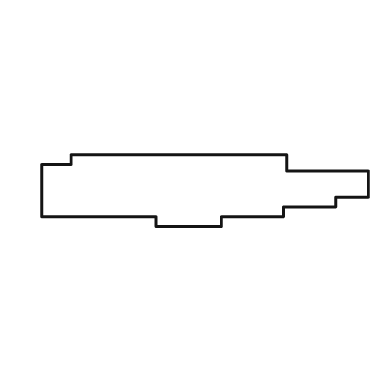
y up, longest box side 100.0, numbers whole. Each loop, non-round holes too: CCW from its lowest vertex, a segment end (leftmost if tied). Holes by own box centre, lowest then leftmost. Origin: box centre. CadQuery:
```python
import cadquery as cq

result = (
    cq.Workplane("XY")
    .moveTo(-15.0, -11.0)
    .lineTo(5.0, -11.0)
    .lineTo(5.0, -8.0)
    .lineTo(24.0, -8.0)
    .lineTo(24.0, -5.0)
    .lineTo(40.0, -5.0)
    .lineTo(40.0, -2.0)
    .lineTo(50.0, -2.0)
    .lineTo(50.0, 6.0)
    .lineTo(25.0, 6.0)
    .lineTo(25.0, 11.0)
    .lineTo(-41.0, 11.0)
    .lineTo(-41.0, 8.0)
    .lineTo(-50.0, 8.0)
    .lineTo(-50.0, -8.0)
    .lineTo(-15.0, -8.0)
    .close()
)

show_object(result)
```